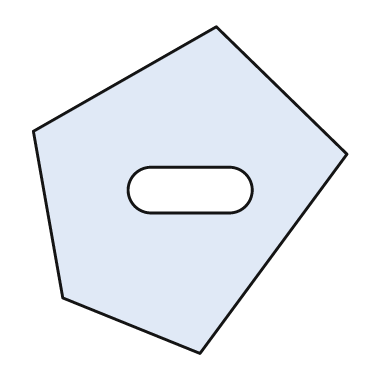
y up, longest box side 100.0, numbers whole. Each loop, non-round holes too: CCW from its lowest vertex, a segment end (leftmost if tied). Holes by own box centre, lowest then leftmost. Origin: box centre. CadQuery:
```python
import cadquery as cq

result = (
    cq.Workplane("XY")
    .moveTo(3.0, -50.0)
    .lineTo(48.0, 11.0)
    .lineTo(8.0, 50.0)
    .lineTo(-48.0, 18.0)
    .lineTo(-39.0, -33.0)
    .close()
    .moveTo(-12.0, -7.0)
    .lineTo(12.0, -7.0)
    .threePointArc((19.0, 0.0), (12.0, 7.0))
    .lineTo(-12.0, 7.0)
    .threePointArc((-19.0, 0.0), (-12.0, -7.0))
    .close()
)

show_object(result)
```